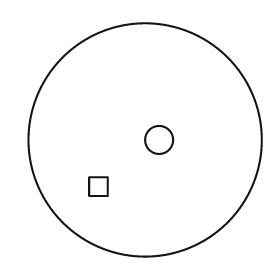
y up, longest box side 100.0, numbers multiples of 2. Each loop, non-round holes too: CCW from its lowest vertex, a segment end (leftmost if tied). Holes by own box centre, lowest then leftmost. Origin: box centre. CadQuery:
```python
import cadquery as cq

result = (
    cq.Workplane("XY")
    .moveTo(0.0, 0.0)
    .circle(50.0)
    .moveTo(-24.0, -24.0)
    .lineTo(-16.0, -24.0)
    .lineTo(-16.0, -16.0)
    .lineTo(-24.0, -16.0)
    .close()
    .moveTo(6.0, 0.0)
    .circle(6.0)
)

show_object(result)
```